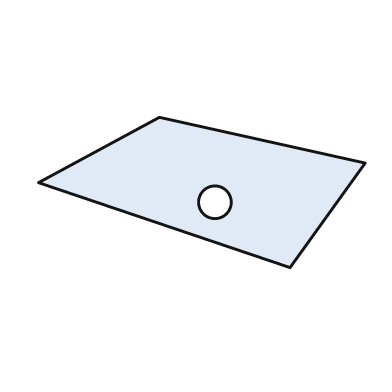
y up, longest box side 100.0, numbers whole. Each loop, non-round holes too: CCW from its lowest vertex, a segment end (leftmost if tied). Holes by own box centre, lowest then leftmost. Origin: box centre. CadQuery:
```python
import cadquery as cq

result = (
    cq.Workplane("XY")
    .moveTo(27.0, -23.0)
    .lineTo(50.0, 9.0)
    .lineTo(-13.0, 23.0)
    .lineTo(-50.0, 3.0)
    .close()
    .moveTo(4.0, -3.0)
    .circle(5.0)
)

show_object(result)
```